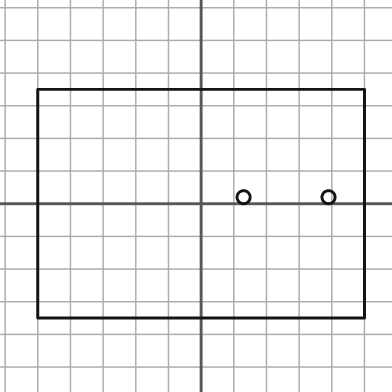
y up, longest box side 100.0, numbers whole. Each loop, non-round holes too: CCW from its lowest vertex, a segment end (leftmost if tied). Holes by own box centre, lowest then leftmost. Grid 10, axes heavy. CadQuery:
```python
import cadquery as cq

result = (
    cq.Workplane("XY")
    .moveTo(-50.0, -35.0)
    .lineTo(50.0, -35.0)
    .lineTo(50.0, 35.0)
    .lineTo(-50.0, 35.0)
    .close()
    .moveTo(13.0, 2.0)
    .circle(2.0)
    .moveTo(39.0, 2.0)
    .circle(2.0)
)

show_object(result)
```